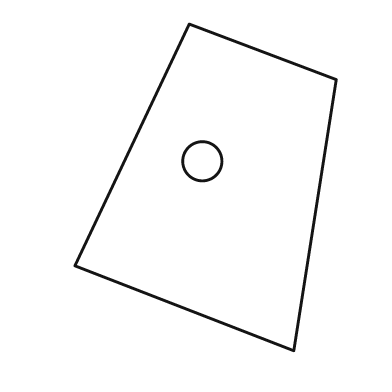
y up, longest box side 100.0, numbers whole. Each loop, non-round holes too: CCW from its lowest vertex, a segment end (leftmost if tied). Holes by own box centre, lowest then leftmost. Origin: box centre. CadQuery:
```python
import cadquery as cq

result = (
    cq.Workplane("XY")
    .moveTo(27.0, -50.0)
    .lineTo(40.0, 33.0)
    .lineTo(-5.0, 50.0)
    .lineTo(-40.0, -24.0)
    .close()
    .moveTo(-1.0, 8.0)
    .circle(6.0)
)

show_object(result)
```